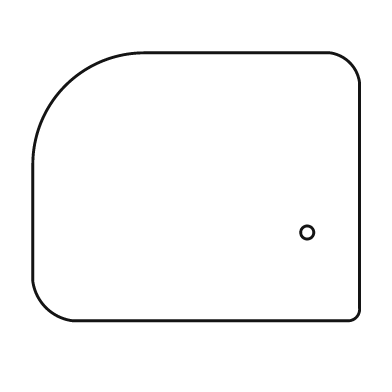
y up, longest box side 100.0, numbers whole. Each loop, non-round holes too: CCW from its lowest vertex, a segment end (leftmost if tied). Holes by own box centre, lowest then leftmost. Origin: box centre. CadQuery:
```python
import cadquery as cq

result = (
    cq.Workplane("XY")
    .moveTo(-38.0, -41.0)
    .lineTo(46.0, -41.0)
    .threePointArc((49.0, -40.0), (50.0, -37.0))
    .lineTo(50.0, 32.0)
    .threePointArc((47.0, 38.0), (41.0, 41.0))
    .lineTo(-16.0, 41.0)
    .threePointArc((-40.0, 31.0), (-50.0, 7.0))
    .lineTo(-50.0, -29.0)
    .threePointArc((-46.0, -37.0), (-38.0, -41.0))
    .close()
    .moveTo(34.0, -14.0)
    .circle(2.0)
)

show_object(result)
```